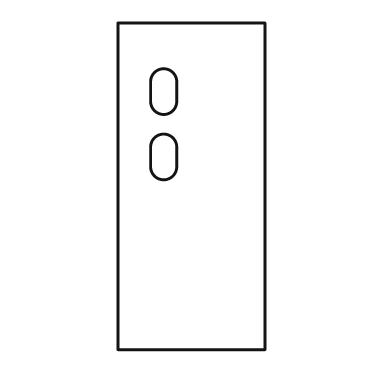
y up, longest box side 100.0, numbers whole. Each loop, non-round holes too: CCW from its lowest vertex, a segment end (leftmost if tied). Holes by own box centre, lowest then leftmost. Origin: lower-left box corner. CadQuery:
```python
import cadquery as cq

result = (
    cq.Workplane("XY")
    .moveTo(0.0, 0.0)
    .lineTo(45.0, 0.0)
    .lineTo(45.0, 100.0)
    .lineTo(0.0, 100.0)
    .close()
    .moveTo(10.0, 56.0)
    .threePointArc((14.0, 52.0), (18.0, 56.0))
    .lineTo(18.0, 62.0)
    .threePointArc((14.0, 66.0), (10.0, 62.0))
    .close()
    .moveTo(10.0, 76.0)
    .threePointArc((14.0, 72.0), (18.0, 76.0))
    .lineTo(18.0, 82.0)
    .threePointArc((14.0, 86.0), (10.0, 82.0))
    .close()
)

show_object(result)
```